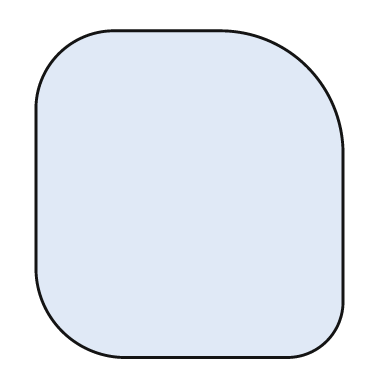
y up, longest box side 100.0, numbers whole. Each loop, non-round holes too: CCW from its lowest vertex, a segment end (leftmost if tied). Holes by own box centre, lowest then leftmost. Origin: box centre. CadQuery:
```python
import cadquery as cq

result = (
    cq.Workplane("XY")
    .moveTo(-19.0, -50.0)
    .lineTo(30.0, -50.0)
    .threePointArc((42.0, -45.0), (47.0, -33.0))
    .lineTo(47.0, 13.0)
    .threePointArc((36.0, 39.0), (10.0, 50.0))
    .lineTo(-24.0, 50.0)
    .threePointArc((-40.0, 43.0), (-47.0, 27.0))
    .lineTo(-47.0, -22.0)
    .threePointArc((-39.0, -42.0), (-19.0, -50.0))
    .close()
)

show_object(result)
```